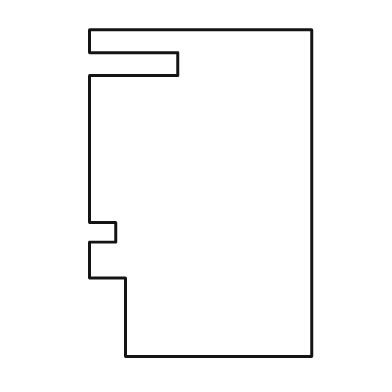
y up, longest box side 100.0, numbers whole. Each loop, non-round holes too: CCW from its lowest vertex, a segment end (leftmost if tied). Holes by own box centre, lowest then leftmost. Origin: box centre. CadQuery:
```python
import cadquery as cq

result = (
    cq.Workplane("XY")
    .moveTo(-23.0, -50.0)
    .lineTo(34.0, -50.0)
    .lineTo(34.0, 50.0)
    .lineTo(-34.0, 50.0)
    .lineTo(-34.0, 43.0)
    .lineTo(-7.0, 43.0)
    .lineTo(-7.0, 36.0)
    .lineTo(-34.0, 36.0)
    .lineTo(-34.0, -9.0)
    .lineTo(-26.0, -9.0)
    .lineTo(-26.0, -15.0)
    .lineTo(-34.0, -15.0)
    .lineTo(-34.0, -26.0)
    .lineTo(-23.0, -26.0)
    .close()
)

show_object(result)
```